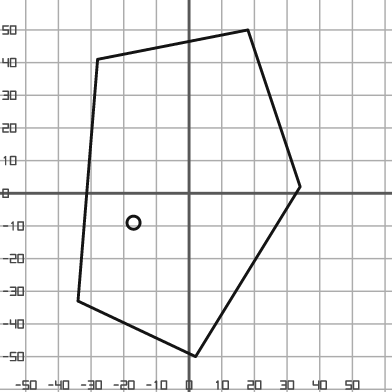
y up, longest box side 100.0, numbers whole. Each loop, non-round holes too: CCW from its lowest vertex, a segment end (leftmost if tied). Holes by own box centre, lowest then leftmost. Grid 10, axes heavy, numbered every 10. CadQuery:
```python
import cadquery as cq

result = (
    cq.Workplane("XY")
    .moveTo(2.0, -50.0)
    .lineTo(34.0, 2.0)
    .lineTo(18.0, 50.0)
    .lineTo(-28.0, 41.0)
    .lineTo(-34.0, -33.0)
    .close()
    .moveTo(-17.0, -9.0)
    .circle(2.0)
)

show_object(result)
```